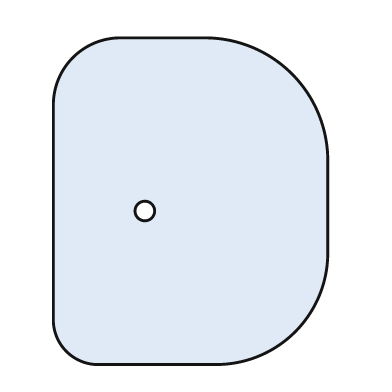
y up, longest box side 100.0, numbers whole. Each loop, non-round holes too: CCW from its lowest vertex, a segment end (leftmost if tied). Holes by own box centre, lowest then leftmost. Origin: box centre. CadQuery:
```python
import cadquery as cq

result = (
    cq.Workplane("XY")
    .moveTo(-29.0, -50.0)
    .lineTo(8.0, -50.0)
    .threePointArc((32.0, -40.0), (42.0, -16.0))
    .lineTo(42.0, 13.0)
    .threePointArc((31.0, 39.0), (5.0, 50.0))
    .lineTo(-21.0, 50.0)
    .threePointArc((-36.0, 44.0), (-42.0, 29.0))
    .lineTo(-42.0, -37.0)
    .threePointArc((-38.0, -46.0), (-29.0, -50.0))
    .close()
    .moveTo(-14.0, -3.0)
    .circle(3.0)
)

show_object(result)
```